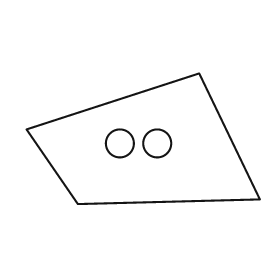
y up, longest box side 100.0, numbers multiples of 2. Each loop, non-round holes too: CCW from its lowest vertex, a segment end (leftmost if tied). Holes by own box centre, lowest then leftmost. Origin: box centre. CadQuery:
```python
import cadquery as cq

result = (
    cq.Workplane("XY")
    .moveTo(-28.0, -28.0)
    .lineTo(50.0, -26.0)
    .lineTo(24.0, 28.0)
    .lineTo(-50.0, 4.0)
    .close()
    .moveTo(-10.0, -2.0)
    .circle(6.0)
    .moveTo(6.0, -2.0)
    .circle(6.0)
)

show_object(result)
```